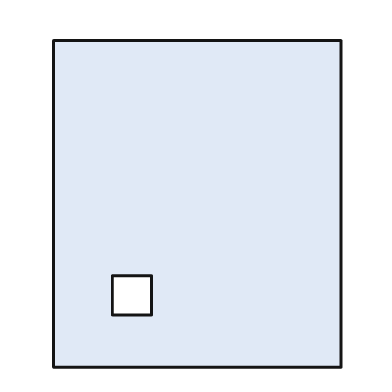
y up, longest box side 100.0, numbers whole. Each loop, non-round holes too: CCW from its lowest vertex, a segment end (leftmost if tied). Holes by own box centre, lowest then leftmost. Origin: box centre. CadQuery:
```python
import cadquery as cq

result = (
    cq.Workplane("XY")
    .moveTo(-44.0, -50.0)
    .lineTo(44.0, -50.0)
    .lineTo(44.0, 50.0)
    .lineTo(-44.0, 50.0)
    .close()
    .moveTo(-26.0, -34.0)
    .lineTo(-14.0, -34.0)
    .lineTo(-14.0, -22.0)
    .lineTo(-26.0, -22.0)
    .close()
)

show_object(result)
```